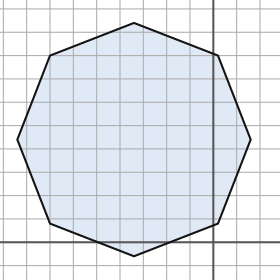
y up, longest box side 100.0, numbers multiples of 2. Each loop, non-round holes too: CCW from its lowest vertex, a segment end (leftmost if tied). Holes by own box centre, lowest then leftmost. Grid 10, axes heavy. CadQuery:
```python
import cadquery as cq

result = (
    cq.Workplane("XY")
    .moveTo(-34.0, -6.0)
    .lineTo(2.0, 8.0)
    .lineTo(16.0, 44.0)
    .lineTo(2.0, 80.0)
    .lineTo(-34.0, 94.0)
    .lineTo(-70.0, 80.0)
    .lineTo(-84.0, 44.0)
    .lineTo(-70.0, 8.0)
    .close()
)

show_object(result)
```